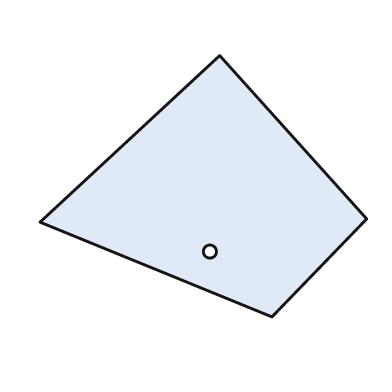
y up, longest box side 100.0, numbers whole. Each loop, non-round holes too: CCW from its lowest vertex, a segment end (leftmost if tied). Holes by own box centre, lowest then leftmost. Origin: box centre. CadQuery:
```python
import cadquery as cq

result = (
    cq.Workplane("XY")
    .moveTo(21.0, -40.0)
    .lineTo(50.0, -10.0)
    .lineTo(5.0, 40.0)
    .lineTo(-50.0, -11.0)
    .close()
    .moveTo(2.0, -20.0)
    .circle(2.0)
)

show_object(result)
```